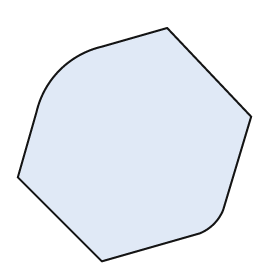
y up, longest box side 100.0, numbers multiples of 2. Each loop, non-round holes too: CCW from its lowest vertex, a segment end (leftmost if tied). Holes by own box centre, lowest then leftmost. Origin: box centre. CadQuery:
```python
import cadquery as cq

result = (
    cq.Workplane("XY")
    .moveTo(-14.0, -50.0)
    .lineTo(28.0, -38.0)
    .threePointArc((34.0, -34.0), (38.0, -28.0))
    .lineTo(50.0, 12.0)
    .lineTo(14.0, 50.0)
    .lineTo(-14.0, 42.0)
    .threePointArc((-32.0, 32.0), (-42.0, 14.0))
    .lineTo(-50.0, -14.0)
    .close()
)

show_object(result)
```